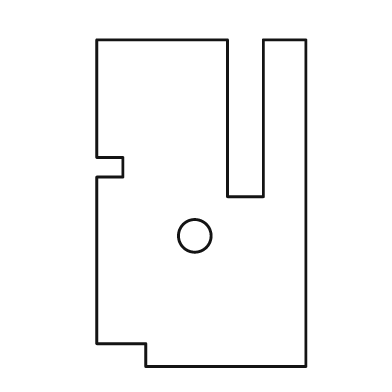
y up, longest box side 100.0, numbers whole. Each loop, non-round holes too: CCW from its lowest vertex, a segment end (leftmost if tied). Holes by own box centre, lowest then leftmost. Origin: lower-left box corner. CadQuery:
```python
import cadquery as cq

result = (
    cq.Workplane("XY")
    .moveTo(15.0, 0.0)
    .lineTo(64.0, 0.0)
    .lineTo(64.0, 100.0)
    .lineTo(51.0, 100.0)
    .lineTo(51.0, 52.0)
    .lineTo(40.0, 52.0)
    .lineTo(40.0, 100.0)
    .lineTo(0.0, 100.0)
    .lineTo(0.0, 64.0)
    .lineTo(8.0, 64.0)
    .lineTo(8.0, 58.0)
    .lineTo(0.0, 58.0)
    .lineTo(0.0, 7.0)
    .lineTo(15.0, 7.0)
    .close()
    .moveTo(30.0, 40.0)
    .circle(5.0)
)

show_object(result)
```